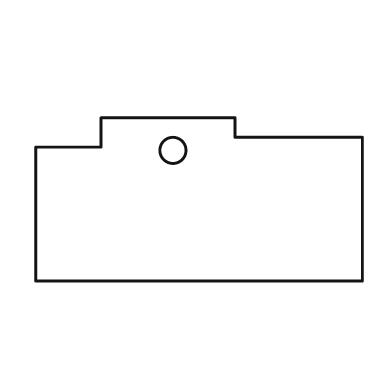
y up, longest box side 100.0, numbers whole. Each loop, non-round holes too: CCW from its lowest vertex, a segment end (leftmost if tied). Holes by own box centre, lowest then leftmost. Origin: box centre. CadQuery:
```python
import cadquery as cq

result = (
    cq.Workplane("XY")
    .moveTo(-50.0, -25.0)
    .lineTo(50.0, -25.0)
    .lineTo(50.0, 19.0)
    .lineTo(11.0, 19.0)
    .lineTo(11.0, 25.0)
    .lineTo(-30.0, 25.0)
    .lineTo(-30.0, 16.0)
    .lineTo(-50.0, 16.0)
    .close()
    .moveTo(-8.0, 15.0)
    .circle(4.0)
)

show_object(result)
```